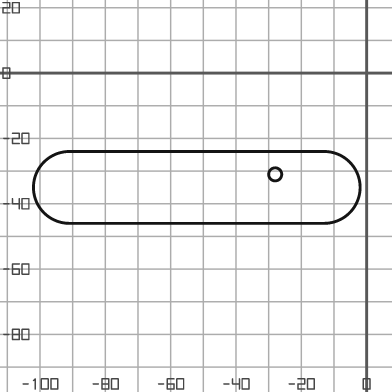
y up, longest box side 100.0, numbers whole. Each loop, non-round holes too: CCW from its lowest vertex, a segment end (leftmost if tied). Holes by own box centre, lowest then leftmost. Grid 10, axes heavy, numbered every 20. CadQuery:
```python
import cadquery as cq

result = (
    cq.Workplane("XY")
    .moveTo(-91.0, -46.0)
    .lineTo(-13.0, -46.0)
    .threePointArc((-2.0, -35.0), (-13.0, -24.0))
    .lineTo(-91.0, -24.0)
    .threePointArc((-102.0, -35.0), (-91.0, -46.0))
    .close()
    .moveTo(-28.0, -31.0)
    .circle(2.0)
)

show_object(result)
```